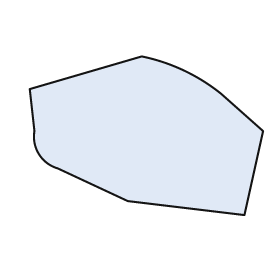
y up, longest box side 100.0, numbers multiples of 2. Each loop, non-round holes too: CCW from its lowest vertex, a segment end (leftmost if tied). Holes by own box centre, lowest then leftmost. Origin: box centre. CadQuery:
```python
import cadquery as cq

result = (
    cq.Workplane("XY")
    .moveTo(42.0, -34.0)
    .lineTo(50.0, 2.0)
    .lineTo(32.0, 18.0)
    .threePointArc((16.0, 28.0), (-2.0, 34.0))
    .lineTo(-50.0, 20.0)
    .lineTo(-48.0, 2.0)
    .threePointArc((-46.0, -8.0), (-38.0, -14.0))
    .lineTo(-8.0, -28.0)
    .close()
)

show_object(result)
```